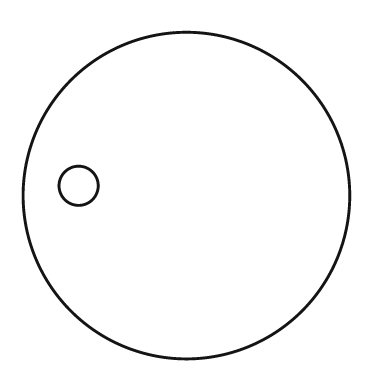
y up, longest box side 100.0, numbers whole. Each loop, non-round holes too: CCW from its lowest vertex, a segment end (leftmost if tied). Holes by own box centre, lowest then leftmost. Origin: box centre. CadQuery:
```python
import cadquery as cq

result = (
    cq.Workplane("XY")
    .moveTo(0.0, 0.0)
    .circle(50.0)
    .moveTo(-33.0, 3.0)
    .circle(6.0)
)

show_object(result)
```